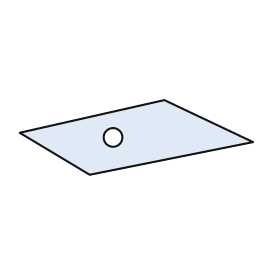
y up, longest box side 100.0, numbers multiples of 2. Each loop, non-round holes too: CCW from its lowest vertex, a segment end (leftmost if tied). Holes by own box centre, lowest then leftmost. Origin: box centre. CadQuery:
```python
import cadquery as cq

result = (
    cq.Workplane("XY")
    .moveTo(-20.0, -16.0)
    .lineTo(50.0, -2.0)
    .lineTo(12.0, 16.0)
    .lineTo(-50.0, 2.0)
    .close()
    .moveTo(-10.0, 0.0)
    .circle(4.0)
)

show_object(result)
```